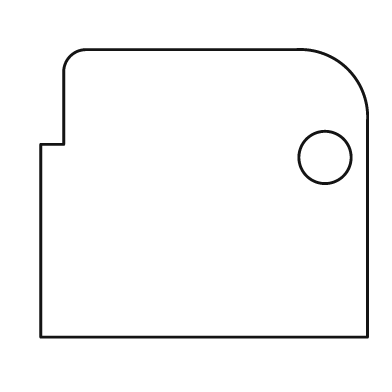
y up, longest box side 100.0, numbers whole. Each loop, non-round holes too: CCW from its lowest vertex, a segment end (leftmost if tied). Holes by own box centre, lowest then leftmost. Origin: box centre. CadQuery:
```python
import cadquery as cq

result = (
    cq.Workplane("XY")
    .moveTo(-50.0, -44.0)
    .lineTo(50.0, -44.0)
    .lineTo(50.0, 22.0)
    .threePointArc((44.0, 38.0), (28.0, 44.0))
    .lineTo(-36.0, 44.0)
    .threePointArc((-41.0, 42.0), (-43.0, 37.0))
    .lineTo(-43.0, 15.0)
    .lineTo(-50.0, 15.0)
    .close()
    .moveTo(37.0, 11.0)
    .circle(8.0)
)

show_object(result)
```